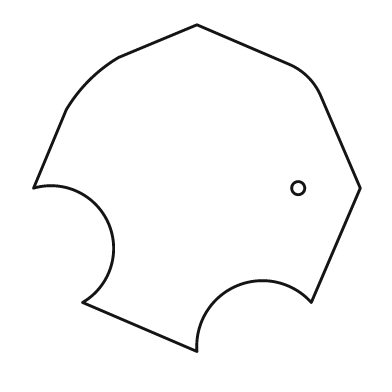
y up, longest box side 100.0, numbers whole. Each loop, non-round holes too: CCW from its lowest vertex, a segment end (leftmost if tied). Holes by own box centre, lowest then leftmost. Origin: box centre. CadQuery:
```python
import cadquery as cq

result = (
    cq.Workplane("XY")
    .moveTo(0.0, -50.0)
    .threePointArc((12.0, -30.0), (35.0, -35.0))
    .lineTo(50.0, 0.0)
    .lineTo(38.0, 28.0)
    .threePointArc((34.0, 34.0), (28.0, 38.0))
    .lineTo(0.0, 50.0)
    .lineTo(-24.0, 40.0)
    .threePointArc((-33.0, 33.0), (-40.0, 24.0))
    .lineTo(-50.0, 0.0)
    .threePointArc((-27.0, -11.0), (-35.0, -35.0))
    .close()
    .moveTo(31.0, 0.0)
    .circle(2.0)
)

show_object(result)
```